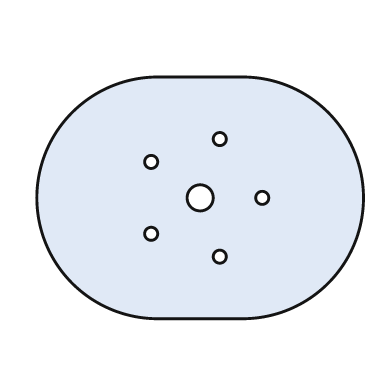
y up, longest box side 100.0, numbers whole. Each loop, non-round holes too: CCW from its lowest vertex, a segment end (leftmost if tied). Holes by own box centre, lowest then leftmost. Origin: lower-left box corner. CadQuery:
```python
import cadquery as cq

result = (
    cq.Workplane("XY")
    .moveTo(37.0, 0.0)
    .lineTo(63.0, 0.0)
    .threePointArc((100.0, 37.0), (63.0, 74.0))
    .lineTo(37.0, 74.0)
    .threePointArc((0.0, 37.0), (37.0, 0.0))
    .close()
    .moveTo(56.0, 19.0)
    .circle(2.0)
    .moveTo(35.0, 26.0)
    .circle(2.0)
    .moveTo(50.0, 37.0)
    .circle(4.0)
    .moveTo(69.0, 37.0)
    .circle(2.0)
    .moveTo(35.0, 48.0)
    .circle(2.0)
    .moveTo(56.0, 55.0)
    .circle(2.0)
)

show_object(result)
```